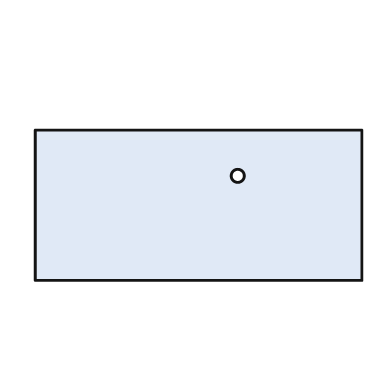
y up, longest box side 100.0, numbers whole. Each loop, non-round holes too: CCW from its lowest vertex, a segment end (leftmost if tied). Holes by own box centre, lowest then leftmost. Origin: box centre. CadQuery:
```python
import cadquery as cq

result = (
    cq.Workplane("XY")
    .moveTo(-50.0, -23.0)
    .lineTo(50.0, -23.0)
    .lineTo(50.0, 23.0)
    .lineTo(-50.0, 23.0)
    .close()
    .moveTo(12.0, 9.0)
    .circle(2.0)
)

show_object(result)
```